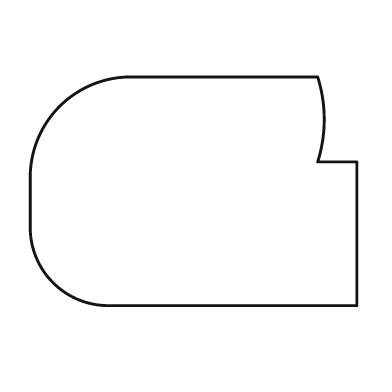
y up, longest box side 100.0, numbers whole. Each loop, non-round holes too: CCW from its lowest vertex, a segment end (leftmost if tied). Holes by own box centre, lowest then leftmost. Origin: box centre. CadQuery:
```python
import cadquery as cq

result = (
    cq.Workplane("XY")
    .moveTo(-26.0, -35.0)
    .lineTo(50.0, -35.0)
    .lineTo(50.0, 9.0)
    .lineTo(38.0, 9.0)
    .threePointArc((40.0, 22.0), (38.0, 35.0))
    .lineTo(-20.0, 35.0)
    .threePointArc((-41.0, 26.0), (-50.0, 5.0))
    .lineTo(-50.0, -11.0)
    .threePointArc((-43.0, -28.0), (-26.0, -35.0))
    .close()
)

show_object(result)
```